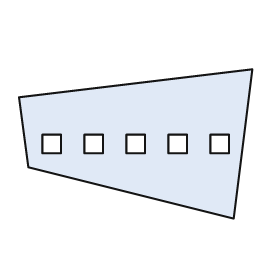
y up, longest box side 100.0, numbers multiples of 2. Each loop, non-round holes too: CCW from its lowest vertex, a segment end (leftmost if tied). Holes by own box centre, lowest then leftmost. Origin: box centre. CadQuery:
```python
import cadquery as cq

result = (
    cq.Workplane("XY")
    .moveTo(42.0, -32.0)
    .lineTo(50.0, 32.0)
    .lineTo(-50.0, 20.0)
    .lineTo(-46.0, -10.0)
    .close()
    .moveTo(-40.0, -4.0)
    .lineTo(-32.0, -4.0)
    .lineTo(-32.0, 4.0)
    .lineTo(-40.0, 4.0)
    .close()
    .moveTo(-22.0, -4.0)
    .lineTo(-14.0, -4.0)
    .lineTo(-14.0, 4.0)
    .lineTo(-22.0, 4.0)
    .close()
    .moveTo(-4.0, -4.0)
    .lineTo(4.0, -4.0)
    .lineTo(4.0, 4.0)
    .lineTo(-4.0, 4.0)
    .close()
    .moveTo(14.0, -4.0)
    .lineTo(22.0, -4.0)
    .lineTo(22.0, 4.0)
    .lineTo(14.0, 4.0)
    .close()
    .moveTo(32.0, -4.0)
    .lineTo(40.0, -4.0)
    .lineTo(40.0, 4.0)
    .lineTo(32.0, 4.0)
    .close()
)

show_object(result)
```